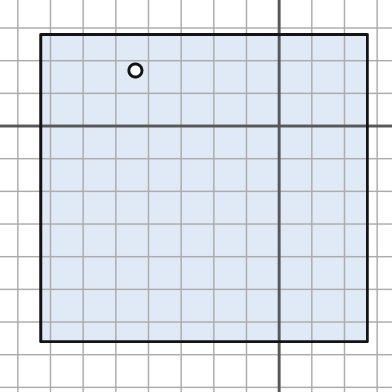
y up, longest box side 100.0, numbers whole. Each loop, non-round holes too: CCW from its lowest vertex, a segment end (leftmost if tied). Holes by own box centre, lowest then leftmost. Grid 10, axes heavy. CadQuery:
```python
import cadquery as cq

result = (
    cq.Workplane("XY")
    .moveTo(-73.0, -66.0)
    .lineTo(27.0, -66.0)
    .lineTo(27.0, 28.0)
    .lineTo(-73.0, 28.0)
    .close()
    .moveTo(-44.0, 17.0)
    .circle(2.0)
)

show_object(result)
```